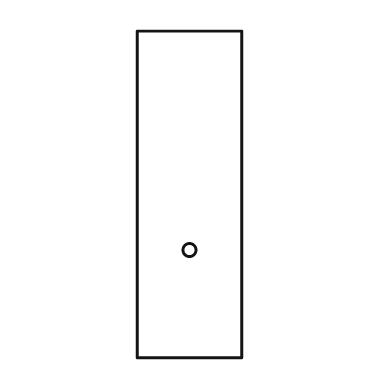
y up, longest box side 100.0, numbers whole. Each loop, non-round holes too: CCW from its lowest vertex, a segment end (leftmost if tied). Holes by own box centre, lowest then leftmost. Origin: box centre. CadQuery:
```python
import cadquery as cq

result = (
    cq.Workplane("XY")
    .moveTo(-16.0, -50.0)
    .lineTo(16.0, -50.0)
    .lineTo(16.0, 50.0)
    .lineTo(-16.0, 50.0)
    .close()
    .moveTo(0.0, -17.0)
    .circle(2.0)
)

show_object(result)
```